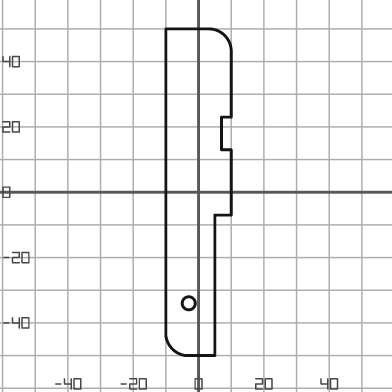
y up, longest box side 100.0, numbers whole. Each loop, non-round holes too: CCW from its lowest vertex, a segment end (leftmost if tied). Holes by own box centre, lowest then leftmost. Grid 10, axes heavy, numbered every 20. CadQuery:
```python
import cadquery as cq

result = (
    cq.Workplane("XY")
    .moveTo(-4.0, -50.0)
    .lineTo(5.0, -50.0)
    .lineTo(5.0, -7.0)
    .lineTo(10.0, -7.0)
    .lineTo(10.0, 13.0)
    .lineTo(7.0, 13.0)
    .lineTo(7.0, 23.0)
    .lineTo(10.0, 23.0)
    .lineTo(10.0, 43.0)
    .threePointArc((8.0, 48.0), (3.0, 50.0))
    .lineTo(-10.0, 50.0)
    .lineTo(-10.0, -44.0)
    .threePointArc((-8.0, -48.0), (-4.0, -50.0))
    .close()
    .moveTo(-3.0, -34.0)
    .circle(2.0)
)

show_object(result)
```